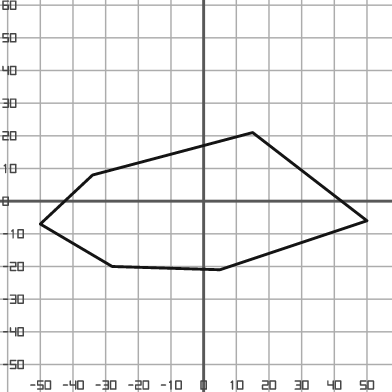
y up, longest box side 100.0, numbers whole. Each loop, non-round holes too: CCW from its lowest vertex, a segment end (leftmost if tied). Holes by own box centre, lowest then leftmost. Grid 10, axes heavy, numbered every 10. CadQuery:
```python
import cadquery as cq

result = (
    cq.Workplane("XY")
    .moveTo(5.0, -21.0)
    .lineTo(50.0, -6.0)
    .lineTo(15.0, 21.0)
    .lineTo(-34.0, 8.0)
    .lineTo(-50.0, -7.0)
    .lineTo(-28.0, -20.0)
    .close()
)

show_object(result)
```